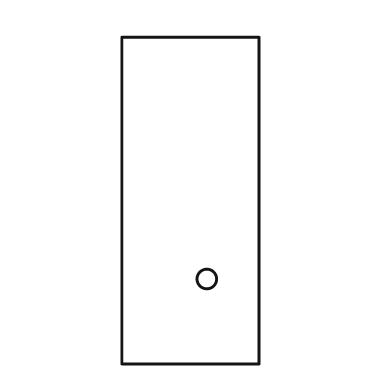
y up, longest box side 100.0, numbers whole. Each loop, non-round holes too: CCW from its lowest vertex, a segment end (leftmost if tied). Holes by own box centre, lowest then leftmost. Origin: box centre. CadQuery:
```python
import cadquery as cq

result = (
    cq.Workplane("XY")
    .moveTo(-21.0, -50.0)
    .lineTo(21.0, -50.0)
    .lineTo(21.0, 50.0)
    .lineTo(-21.0, 50.0)
    .close()
    .moveTo(5.0, -24.0)
    .circle(3.0)
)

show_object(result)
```